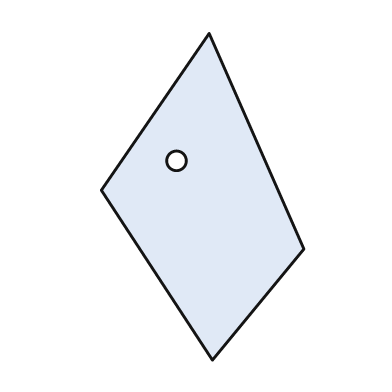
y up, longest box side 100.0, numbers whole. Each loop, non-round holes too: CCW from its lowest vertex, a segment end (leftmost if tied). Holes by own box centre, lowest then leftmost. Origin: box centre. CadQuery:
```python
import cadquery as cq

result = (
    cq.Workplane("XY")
    .moveTo(3.0, -50.0)
    .lineTo(31.0, -16.0)
    .lineTo(2.0, 50.0)
    .lineTo(-31.0, 2.0)
    .close()
    .moveTo(-8.0, 11.0)
    .circle(3.0)
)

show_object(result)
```